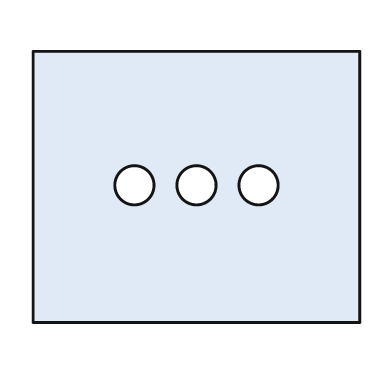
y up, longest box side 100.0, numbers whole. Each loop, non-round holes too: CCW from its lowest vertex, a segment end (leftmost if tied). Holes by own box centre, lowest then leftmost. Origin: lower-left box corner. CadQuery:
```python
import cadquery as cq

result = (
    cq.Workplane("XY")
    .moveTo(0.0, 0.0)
    .lineTo(100.0, 0.0)
    .lineTo(100.0, 83.0)
    .lineTo(0.0, 83.0)
    .close()
    .moveTo(31.0, 42.0)
    .circle(6.0)
    .moveTo(50.0, 42.0)
    .circle(6.0)
    .moveTo(69.0, 42.0)
    .circle(6.0)
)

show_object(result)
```